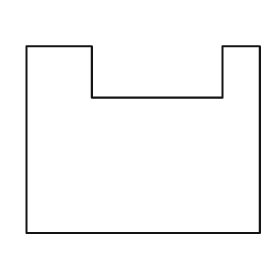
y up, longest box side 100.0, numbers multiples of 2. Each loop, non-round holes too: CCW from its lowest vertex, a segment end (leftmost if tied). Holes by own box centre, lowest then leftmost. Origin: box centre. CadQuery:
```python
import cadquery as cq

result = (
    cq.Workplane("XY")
    .moveTo(-50.0, -40.0)
    .lineTo(50.0, -40.0)
    .lineTo(50.0, 40.0)
    .lineTo(34.0, 40.0)
    .lineTo(34.0, 18.0)
    .lineTo(-22.0, 18.0)
    .lineTo(-22.0, 40.0)
    .lineTo(-50.0, 40.0)
    .close()
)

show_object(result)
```